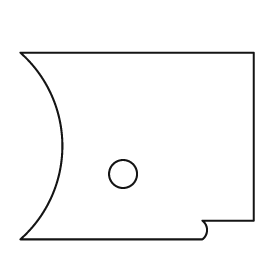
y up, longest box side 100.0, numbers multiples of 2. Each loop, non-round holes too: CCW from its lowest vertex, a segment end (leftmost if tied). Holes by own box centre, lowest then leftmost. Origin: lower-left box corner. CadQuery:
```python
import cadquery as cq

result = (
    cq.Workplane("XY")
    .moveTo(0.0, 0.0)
    .lineTo(78.0, 0.0)
    .threePointArc((80.0, 4.0), (78.0, 8.0))
    .lineTo(100.0, 8.0)
    .lineTo(100.0, 80.0)
    .lineTo(0.0, 80.0)
    .threePointArc((18.0, 40.0), (0.0, 0.0))
    .close()
    .moveTo(44.0, 28.0)
    .circle(6.0)
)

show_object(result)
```